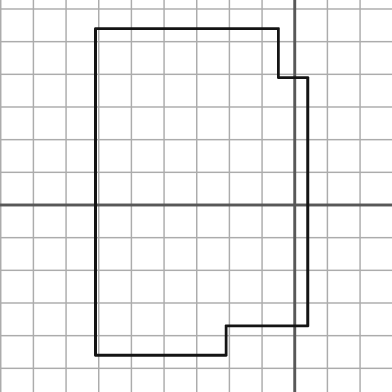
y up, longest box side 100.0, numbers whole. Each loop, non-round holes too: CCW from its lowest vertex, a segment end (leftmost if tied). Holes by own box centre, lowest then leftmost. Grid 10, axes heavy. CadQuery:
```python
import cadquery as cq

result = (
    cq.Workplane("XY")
    .moveTo(-61.0, -46.0)
    .lineTo(-21.0, -46.0)
    .lineTo(-21.0, -37.0)
    .lineTo(4.0, -37.0)
    .lineTo(4.0, 39.0)
    .lineTo(-5.0, 39.0)
    .lineTo(-5.0, 54.0)
    .lineTo(-61.0, 54.0)
    .close()
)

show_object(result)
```